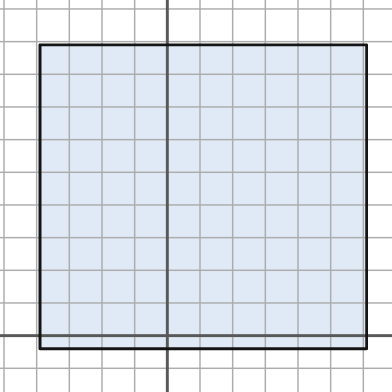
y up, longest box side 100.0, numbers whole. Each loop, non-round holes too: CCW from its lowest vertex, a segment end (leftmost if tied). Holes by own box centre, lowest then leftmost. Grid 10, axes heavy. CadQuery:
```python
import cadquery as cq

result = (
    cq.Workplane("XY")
    .moveTo(-39.0, -4.0)
    .lineTo(61.0, -4.0)
    .lineTo(61.0, 89.0)
    .lineTo(-39.0, 89.0)
    .close()
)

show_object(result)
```